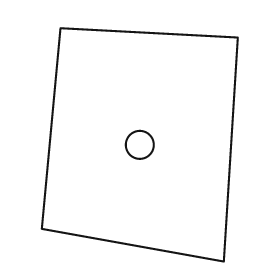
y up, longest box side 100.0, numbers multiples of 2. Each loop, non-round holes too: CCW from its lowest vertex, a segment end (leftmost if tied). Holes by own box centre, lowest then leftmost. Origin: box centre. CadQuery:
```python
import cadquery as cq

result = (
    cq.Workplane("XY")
    .moveTo(36.0, -50.0)
    .lineTo(42.0, 46.0)
    .lineTo(-34.0, 50.0)
    .lineTo(-42.0, -36.0)
    .close()
    .moveTo(0.0, 0.0)
    .circle(6.0)
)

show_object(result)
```